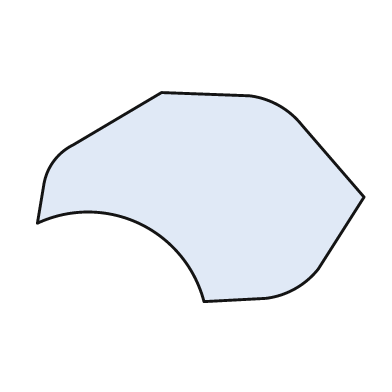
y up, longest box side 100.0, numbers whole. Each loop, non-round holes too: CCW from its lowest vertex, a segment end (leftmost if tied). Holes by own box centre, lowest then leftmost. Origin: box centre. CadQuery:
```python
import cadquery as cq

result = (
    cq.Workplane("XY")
    .moveTo(1.0, -32.0)
    .lineTo(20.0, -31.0)
    .threePointArc((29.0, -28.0), (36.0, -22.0))
    .lineTo(50.0, 0.0)
    .lineTo(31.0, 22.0)
    .threePointArc((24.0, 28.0), (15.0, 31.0))
    .lineTo(-12.0, 32.0)
    .lineTo(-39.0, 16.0)
    .threePointArc((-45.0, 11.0), (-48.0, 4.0))
    .lineTo(-50.0, -8.0)
    .threePointArc((-19.0, -8.0), (1.0, -32.0))
    .close()
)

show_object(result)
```